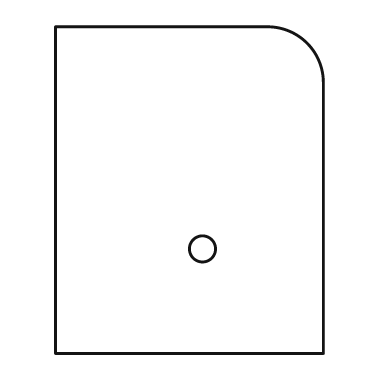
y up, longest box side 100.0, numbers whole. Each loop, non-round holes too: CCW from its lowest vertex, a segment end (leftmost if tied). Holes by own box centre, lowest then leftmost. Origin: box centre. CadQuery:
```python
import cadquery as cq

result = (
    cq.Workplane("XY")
    .moveTo(-41.0, -50.0)
    .lineTo(41.0, -50.0)
    .lineTo(41.0, 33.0)
    .threePointArc((36.0, 45.0), (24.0, 50.0))
    .lineTo(-41.0, 50.0)
    .close()
    .moveTo(4.0, -18.0)
    .circle(4.0)
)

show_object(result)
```